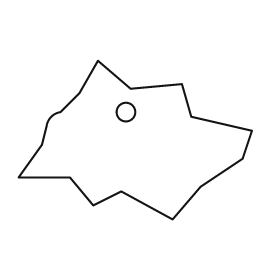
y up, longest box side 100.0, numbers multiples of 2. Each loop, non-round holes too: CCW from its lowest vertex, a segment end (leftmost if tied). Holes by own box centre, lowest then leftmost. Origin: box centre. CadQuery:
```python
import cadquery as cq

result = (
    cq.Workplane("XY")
    .moveTo(16.0, -34.0)
    .lineTo(28.0, -20.0)
    .lineTo(46.0, -8.0)
    .lineTo(50.0, 4.0)
    .lineTo(24.0, 10.0)
    .lineTo(20.0, 24.0)
    .lineTo(-2.0, 22.0)
    .lineTo(-16.0, 34.0)
    .lineTo(-24.0, 20.0)
    .lineTo(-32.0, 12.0)
    .threePointArc((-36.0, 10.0), (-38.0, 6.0))
    .lineTo(-40.0, -2.0)
    .lineTo(-50.0, -16.0)
    .lineTo(-28.0, -16.0)
    .lineTo(-18.0, -28.0)
    .lineTo(-6.0, -22.0)
    .close()
    .moveTo(-4.0, 12.0)
    .circle(4.0)
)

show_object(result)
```